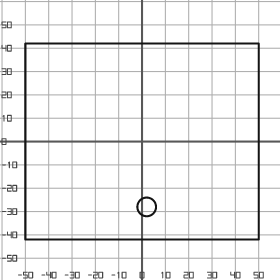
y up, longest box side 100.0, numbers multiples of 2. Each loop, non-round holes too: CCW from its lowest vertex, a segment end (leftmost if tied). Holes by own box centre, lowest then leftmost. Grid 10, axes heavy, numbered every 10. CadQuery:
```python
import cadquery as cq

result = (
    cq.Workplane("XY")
    .moveTo(-50.0, -42.0)
    .lineTo(50.0, -42.0)
    .lineTo(50.0, 42.0)
    .lineTo(-50.0, 42.0)
    .close()
    .moveTo(2.0, -28.0)
    .circle(4.0)
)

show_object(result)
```